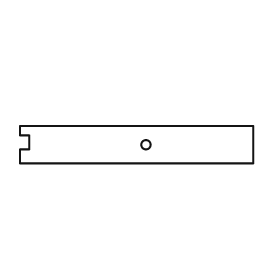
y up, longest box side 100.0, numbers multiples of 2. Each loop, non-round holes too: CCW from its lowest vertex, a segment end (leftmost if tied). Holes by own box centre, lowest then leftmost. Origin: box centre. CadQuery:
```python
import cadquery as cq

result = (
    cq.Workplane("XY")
    .moveTo(-50.0, -8.0)
    .lineTo(50.0, -8.0)
    .lineTo(50.0, 8.0)
    .lineTo(-50.0, 8.0)
    .lineTo(-50.0, 4.0)
    .lineTo(-46.0, 4.0)
    .lineTo(-46.0, -2.0)
    .lineTo(-50.0, -2.0)
    .close()
    .moveTo(4.0, 0.0)
    .circle(2.0)
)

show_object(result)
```